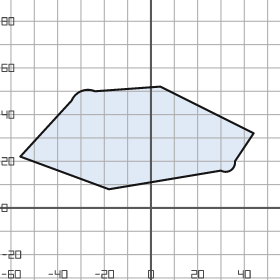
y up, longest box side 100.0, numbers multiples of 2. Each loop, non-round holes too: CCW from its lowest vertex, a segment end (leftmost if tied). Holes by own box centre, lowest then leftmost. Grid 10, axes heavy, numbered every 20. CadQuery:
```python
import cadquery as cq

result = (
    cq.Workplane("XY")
    .moveTo(-18.0, 8.0)
    .lineTo(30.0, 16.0)
    .threePointArc((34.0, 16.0), (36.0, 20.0))
    .lineTo(44.0, 32.0)
    .lineTo(4.0, 52.0)
    .lineTo(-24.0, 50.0)
    .threePointArc((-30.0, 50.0), (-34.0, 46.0))
    .lineTo(-56.0, 22.0)
    .close()
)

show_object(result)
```